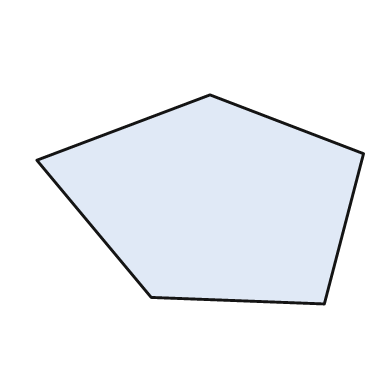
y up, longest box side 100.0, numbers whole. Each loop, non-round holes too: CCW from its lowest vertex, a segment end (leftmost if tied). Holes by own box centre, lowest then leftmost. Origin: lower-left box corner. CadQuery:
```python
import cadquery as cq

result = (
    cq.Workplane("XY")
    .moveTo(88.0, 0.0)
    .lineTo(100.0, 46.0)
    .lineTo(53.0, 64.0)
    .lineTo(0.0, 44.0)
    .lineTo(35.0, 2.0)
    .close()
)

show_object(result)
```